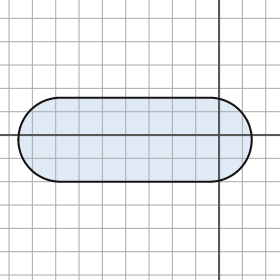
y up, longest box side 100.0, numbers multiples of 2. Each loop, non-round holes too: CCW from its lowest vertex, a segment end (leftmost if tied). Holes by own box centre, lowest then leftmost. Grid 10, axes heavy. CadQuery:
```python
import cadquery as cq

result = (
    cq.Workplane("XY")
    .moveTo(-68.0, -20.0)
    .lineTo(-4.0, -20.0)
    .threePointArc((14.0, -2.0), (-4.0, 16.0))
    .lineTo(-68.0, 16.0)
    .threePointArc((-86.0, -2.0), (-68.0, -20.0))
    .close()
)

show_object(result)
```